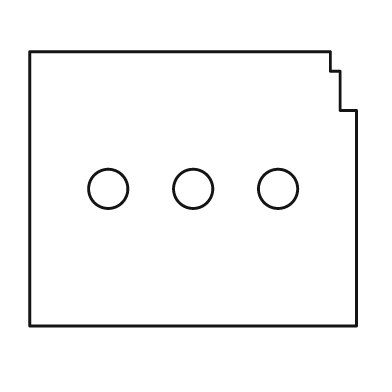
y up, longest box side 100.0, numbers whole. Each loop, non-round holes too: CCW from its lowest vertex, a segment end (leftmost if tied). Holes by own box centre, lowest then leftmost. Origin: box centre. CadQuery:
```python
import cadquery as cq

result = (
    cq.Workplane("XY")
    .moveTo(-50.0, -42.0)
    .lineTo(50.0, -42.0)
    .lineTo(50.0, 24.0)
    .lineTo(45.0, 24.0)
    .lineTo(45.0, 36.0)
    .lineTo(42.0, 36.0)
    .lineTo(42.0, 42.0)
    .lineTo(-50.0, 42.0)
    .close()
    .moveTo(-26.0, 0.0)
    .circle(6.0)
    .moveTo(0.0, 0.0)
    .circle(6.0)
    .moveTo(26.0, 0.0)
    .circle(6.0)
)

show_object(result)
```